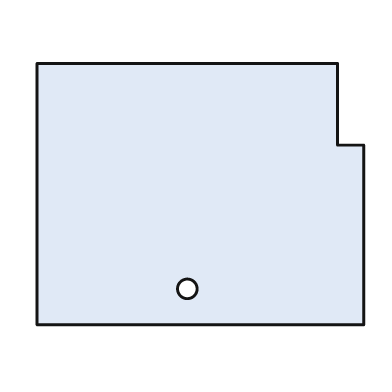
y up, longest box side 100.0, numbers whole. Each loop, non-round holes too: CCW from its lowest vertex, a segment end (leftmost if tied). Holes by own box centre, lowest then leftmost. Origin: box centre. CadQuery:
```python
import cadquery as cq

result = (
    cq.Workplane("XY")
    .moveTo(-50.0, -40.0)
    .lineTo(50.0, -40.0)
    .lineTo(50.0, 15.0)
    .lineTo(42.0, 15.0)
    .lineTo(42.0, 40.0)
    .lineTo(-50.0, 40.0)
    .close()
    .moveTo(-4.0, -29.0)
    .circle(3.0)
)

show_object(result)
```